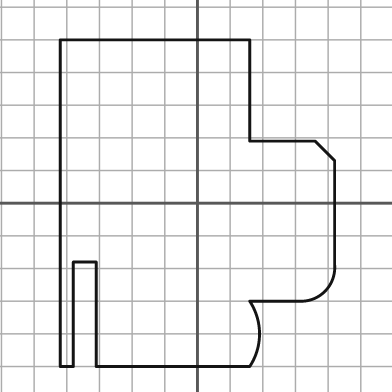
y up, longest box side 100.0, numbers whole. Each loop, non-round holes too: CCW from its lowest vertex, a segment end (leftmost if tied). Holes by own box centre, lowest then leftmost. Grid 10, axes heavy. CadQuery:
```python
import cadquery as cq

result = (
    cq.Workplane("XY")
    .moveTo(-42.0, -50.0)
    .lineTo(-38.0, -50.0)
    .lineTo(-38.0, -18.0)
    .lineTo(-31.0, -18.0)
    .lineTo(-31.0, -50.0)
    .lineTo(16.0, -50.0)
    .threePointArc((19.0, -40.0), (16.0, -30.0))
    .lineTo(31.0, -30.0)
    .threePointArc((39.0, -27.0), (42.0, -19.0))
    .lineTo(42.0, 13.0)
    .lineTo(36.0, 19.0)
    .lineTo(16.0, 19.0)
    .lineTo(16.0, 50.0)
    .lineTo(-42.0, 50.0)
    .close()
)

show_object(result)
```